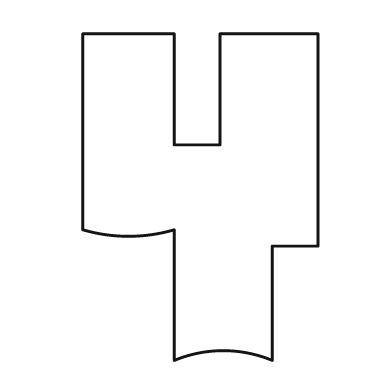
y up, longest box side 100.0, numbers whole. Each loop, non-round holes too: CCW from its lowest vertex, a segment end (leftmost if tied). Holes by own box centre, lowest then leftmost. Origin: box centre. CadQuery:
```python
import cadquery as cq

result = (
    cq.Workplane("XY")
    .moveTo(-8.0, -50.0)
    .threePointArc((7.0, -47.0), (22.0, -50.0))
    .lineTo(22.0, -15.0)
    .lineTo(36.0, -15.0)
    .lineTo(36.0, 50.0)
    .lineTo(6.0, 50.0)
    .lineTo(6.0, 16.0)
    .lineTo(-8.0, 16.0)
    .lineTo(-8.0, 50.0)
    .lineTo(-36.0, 50.0)
    .lineTo(-36.0, -10.0)
    .threePointArc((-22.0, -12.0), (-8.0, -10.0))
    .close()
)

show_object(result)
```